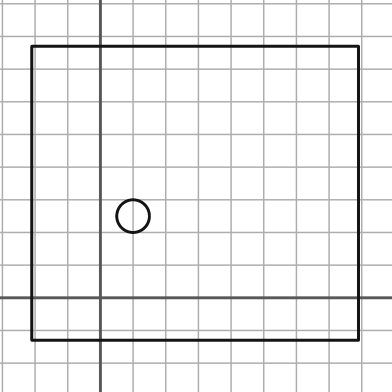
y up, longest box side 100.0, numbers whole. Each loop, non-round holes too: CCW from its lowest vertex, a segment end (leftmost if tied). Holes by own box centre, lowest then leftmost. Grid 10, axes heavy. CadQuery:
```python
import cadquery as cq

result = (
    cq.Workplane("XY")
    .moveTo(-21.0, -13.0)
    .lineTo(79.0, -13.0)
    .lineTo(79.0, 77.0)
    .lineTo(-21.0, 77.0)
    .close()
    .moveTo(10.0, 25.0)
    .circle(5.0)
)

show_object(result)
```